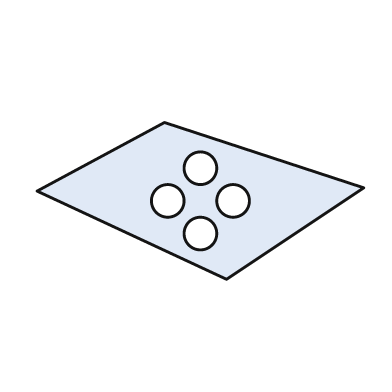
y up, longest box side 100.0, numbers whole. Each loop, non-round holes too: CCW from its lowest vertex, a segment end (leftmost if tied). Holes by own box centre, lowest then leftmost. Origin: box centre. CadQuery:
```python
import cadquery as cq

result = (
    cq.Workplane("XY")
    .moveTo(8.0, -24.0)
    .lineTo(50.0, 4.0)
    .lineTo(-11.0, 24.0)
    .lineTo(-50.0, 3.0)
    .close()
    .moveTo(0.0, -10.0)
    .circle(5.0)
    .moveTo(-10.0, 0.0)
    .circle(5.0)
    .moveTo(10.0, 0.0)
    .circle(5.0)
    .moveTo(0.0, 10.0)
    .circle(5.0)
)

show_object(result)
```